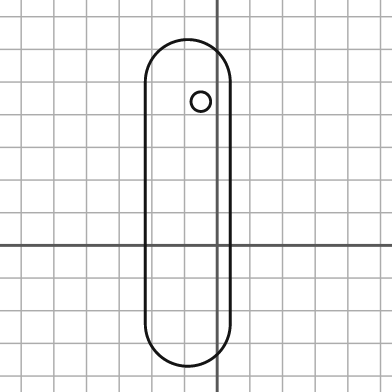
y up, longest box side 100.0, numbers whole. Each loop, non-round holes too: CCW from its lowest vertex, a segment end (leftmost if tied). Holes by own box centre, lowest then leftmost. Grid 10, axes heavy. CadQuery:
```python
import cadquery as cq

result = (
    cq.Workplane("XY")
    .moveTo(-22.0, -24.0)
    .threePointArc((-9.0, -37.0), (4.0, -24.0))
    .lineTo(4.0, 50.0)
    .threePointArc((-9.0, 63.0), (-22.0, 50.0))
    .close()
    .moveTo(-5.0, 44.0)
    .circle(3.0)
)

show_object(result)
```